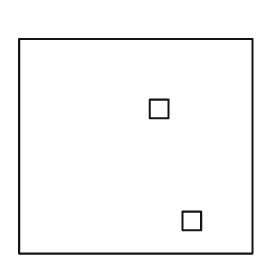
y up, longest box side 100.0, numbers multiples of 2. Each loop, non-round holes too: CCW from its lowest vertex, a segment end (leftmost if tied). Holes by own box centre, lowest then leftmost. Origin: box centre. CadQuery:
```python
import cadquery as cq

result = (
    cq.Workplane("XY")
    .moveTo(-50.0, -46.0)
    .lineTo(50.0, -46.0)
    .lineTo(50.0, 46.0)
    .lineTo(-50.0, 46.0)
    .close()
    .moveTo(20.0, -36.0)
    .lineTo(28.0, -36.0)
    .lineTo(28.0, -28.0)
    .lineTo(20.0, -28.0)
    .close()
    .moveTo(6.0, 12.0)
    .lineTo(14.0, 12.0)
    .lineTo(14.0, 20.0)
    .lineTo(6.0, 20.0)
    .close()
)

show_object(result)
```